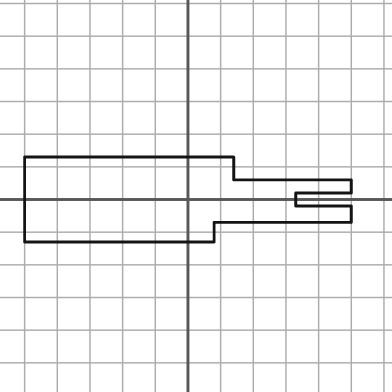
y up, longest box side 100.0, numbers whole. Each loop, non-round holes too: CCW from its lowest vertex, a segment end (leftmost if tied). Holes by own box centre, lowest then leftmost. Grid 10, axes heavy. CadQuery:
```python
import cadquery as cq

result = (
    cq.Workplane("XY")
    .moveTo(-50.0, -13.0)
    .lineTo(8.0, -13.0)
    .lineTo(8.0, -7.0)
    .lineTo(50.0, -7.0)
    .lineTo(50.0, -2.0)
    .lineTo(33.0, -2.0)
    .lineTo(33.0, 2.0)
    .lineTo(50.0, 2.0)
    .lineTo(50.0, 6.0)
    .lineTo(14.0, 6.0)
    .lineTo(14.0, 13.0)
    .lineTo(-50.0, 13.0)
    .close()
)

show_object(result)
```